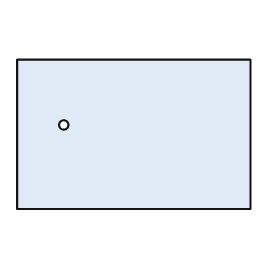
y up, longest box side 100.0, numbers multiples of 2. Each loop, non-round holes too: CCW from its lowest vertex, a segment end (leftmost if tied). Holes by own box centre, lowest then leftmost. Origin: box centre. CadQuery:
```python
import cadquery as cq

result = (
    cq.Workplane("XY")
    .moveTo(-50.0, -32.0)
    .lineTo(50.0, -32.0)
    .lineTo(50.0, 32.0)
    .lineTo(-50.0, 32.0)
    .close()
    .moveTo(-30.0, 4.0)
    .circle(2.0)
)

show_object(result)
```